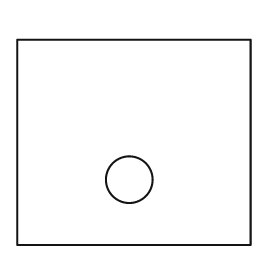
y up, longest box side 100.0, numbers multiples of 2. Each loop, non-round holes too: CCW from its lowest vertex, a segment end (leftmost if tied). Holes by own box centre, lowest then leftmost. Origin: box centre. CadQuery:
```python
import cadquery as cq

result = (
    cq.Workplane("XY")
    .moveTo(-50.0, -44.0)
    .lineTo(50.0, -44.0)
    .lineTo(50.0, 44.0)
    .lineTo(-50.0, 44.0)
    .close()
    .moveTo(-2.0, -16.0)
    .circle(10.0)
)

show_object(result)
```